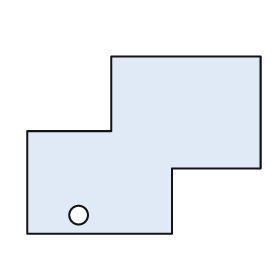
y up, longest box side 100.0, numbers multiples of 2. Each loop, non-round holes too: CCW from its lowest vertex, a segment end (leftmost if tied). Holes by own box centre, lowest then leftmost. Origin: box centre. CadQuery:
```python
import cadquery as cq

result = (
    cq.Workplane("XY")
    .moveTo(-50.0, -38.0)
    .lineTo(12.0, -38.0)
    .lineTo(12.0, -10.0)
    .lineTo(50.0, -10.0)
    .lineTo(50.0, 38.0)
    .lineTo(-14.0, 38.0)
    .lineTo(-14.0, 6.0)
    .lineTo(-50.0, 6.0)
    .close()
    .moveTo(-28.0, -30.0)
    .circle(4.0)
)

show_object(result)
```